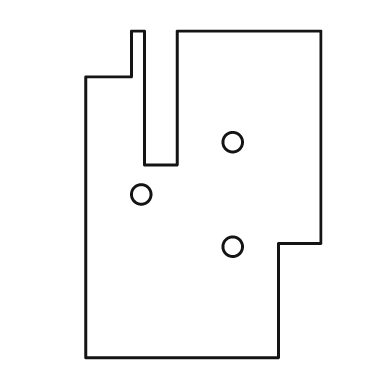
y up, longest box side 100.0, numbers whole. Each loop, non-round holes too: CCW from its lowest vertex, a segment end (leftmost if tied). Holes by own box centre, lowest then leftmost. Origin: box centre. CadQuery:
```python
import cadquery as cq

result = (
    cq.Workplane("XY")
    .moveTo(-36.0, -50.0)
    .lineTo(23.0, -50.0)
    .lineTo(23.0, -15.0)
    .lineTo(36.0, -15.0)
    .lineTo(36.0, 50.0)
    .lineTo(-8.0, 50.0)
    .lineTo(-8.0, 9.0)
    .lineTo(-18.0, 9.0)
    .lineTo(-18.0, 50.0)
    .lineTo(-22.0, 50.0)
    .lineTo(-22.0, 36.0)
    .lineTo(-36.0, 36.0)
    .close()
    .moveTo(9.0, -16.0)
    .circle(3.0)
    .moveTo(-19.0, 0.0)
    .circle(3.0)
    .moveTo(9.0, 16.0)
    .circle(3.0)
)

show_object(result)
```